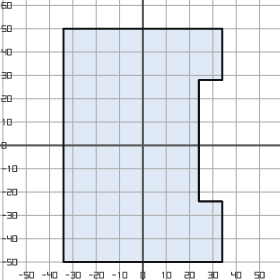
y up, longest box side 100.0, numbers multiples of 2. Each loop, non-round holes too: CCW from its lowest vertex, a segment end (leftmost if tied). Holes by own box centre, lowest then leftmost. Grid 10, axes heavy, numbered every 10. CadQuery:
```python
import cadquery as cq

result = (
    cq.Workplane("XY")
    .moveTo(-34.0, -50.0)
    .lineTo(34.0, -50.0)
    .lineTo(34.0, -24.0)
    .lineTo(24.0, -24.0)
    .lineTo(24.0, 28.0)
    .lineTo(34.0, 28.0)
    .lineTo(34.0, 50.0)
    .lineTo(-34.0, 50.0)
    .close()
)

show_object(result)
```